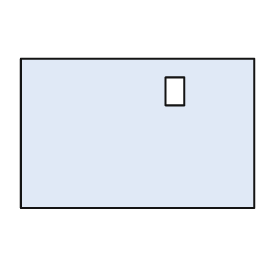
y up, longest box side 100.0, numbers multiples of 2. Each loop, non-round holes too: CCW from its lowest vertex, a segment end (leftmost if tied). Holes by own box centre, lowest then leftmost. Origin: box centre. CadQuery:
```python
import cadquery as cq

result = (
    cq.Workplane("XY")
    .moveTo(-50.0, -32.0)
    .lineTo(50.0, -32.0)
    .lineTo(50.0, 32.0)
    .lineTo(-50.0, 32.0)
    .close()
    .moveTo(12.0, 12.0)
    .lineTo(20.0, 12.0)
    .lineTo(20.0, 24.0)
    .lineTo(12.0, 24.0)
    .close()
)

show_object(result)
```